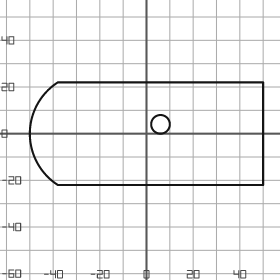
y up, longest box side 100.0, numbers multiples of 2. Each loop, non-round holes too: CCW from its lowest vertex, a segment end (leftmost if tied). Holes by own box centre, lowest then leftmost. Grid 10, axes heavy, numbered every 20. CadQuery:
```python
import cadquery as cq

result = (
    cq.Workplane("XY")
    .moveTo(-38.0, -22.0)
    .lineTo(50.0, -22.0)
    .lineTo(50.0, 22.0)
    .lineTo(-38.0, 22.0)
    .threePointArc((-50.0, 0.0), (-38.0, -22.0))
    .close()
    .moveTo(6.0, 4.0)
    .circle(4.0)
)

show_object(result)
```